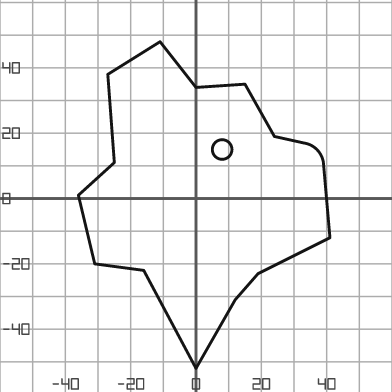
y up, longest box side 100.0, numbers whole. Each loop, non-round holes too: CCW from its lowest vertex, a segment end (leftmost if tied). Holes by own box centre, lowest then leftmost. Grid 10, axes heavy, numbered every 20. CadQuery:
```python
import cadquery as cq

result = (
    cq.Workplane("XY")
    .moveTo(0.0, -52.0)
    .lineTo(12.0, -31.0)
    .lineTo(19.0, -23.0)
    .lineTo(41.0, -12.0)
    .lineTo(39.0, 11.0)
    .threePointArc((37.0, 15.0), (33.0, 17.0))
    .lineTo(24.0, 19.0)
    .lineTo(15.0, 35.0)
    .lineTo(0.0, 34.0)
    .lineTo(-11.0, 48.0)
    .lineTo(-27.0, 38.0)
    .lineTo(-25.0, 11.0)
    .lineTo(-36.0, 1.0)
    .lineTo(-31.0, -20.0)
    .lineTo(-16.0, -22.0)
    .close()
    .moveTo(8.0, 15.0)
    .circle(3.0)
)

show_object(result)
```